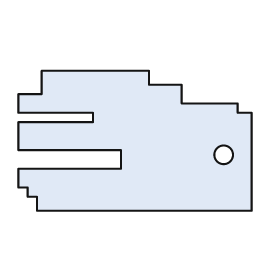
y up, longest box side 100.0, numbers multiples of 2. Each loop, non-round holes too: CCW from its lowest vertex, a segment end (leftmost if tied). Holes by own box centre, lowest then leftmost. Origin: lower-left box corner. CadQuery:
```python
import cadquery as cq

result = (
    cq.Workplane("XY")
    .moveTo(8.0, 0.0)
    .lineTo(100.0, 0.0)
    .lineTo(100.0, 42.0)
    .lineTo(94.0, 42.0)
    .lineTo(94.0, 46.0)
    .lineTo(70.0, 46.0)
    .lineTo(70.0, 54.0)
    .lineTo(56.0, 54.0)
    .lineTo(56.0, 60.0)
    .lineTo(10.0, 60.0)
    .lineTo(10.0, 50.0)
    .lineTo(0.0, 50.0)
    .lineTo(0.0, 42.0)
    .lineTo(32.0, 42.0)
    .lineTo(32.0, 38.0)
    .lineTo(0.0, 38.0)
    .lineTo(0.0, 26.0)
    .lineTo(44.0, 26.0)
    .lineTo(44.0, 18.0)
    .lineTo(0.0, 18.0)
    .lineTo(0.0, 10.0)
    .lineTo(4.0, 10.0)
    .lineTo(4.0, 6.0)
    .lineTo(8.0, 6.0)
    .close()
    .moveTo(88.0, 24.0)
    .circle(4.0)
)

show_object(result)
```